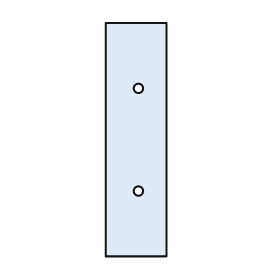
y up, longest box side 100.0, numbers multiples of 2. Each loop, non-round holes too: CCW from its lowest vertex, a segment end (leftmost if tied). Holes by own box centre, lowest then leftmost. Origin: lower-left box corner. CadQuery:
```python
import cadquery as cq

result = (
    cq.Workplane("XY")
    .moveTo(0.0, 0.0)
    .lineTo(26.0, 0.0)
    .lineTo(26.0, 100.0)
    .lineTo(0.0, 100.0)
    .close()
    .moveTo(14.0, 28.0)
    .circle(2.0)
    .moveTo(14.0, 72.0)
    .circle(2.0)
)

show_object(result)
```